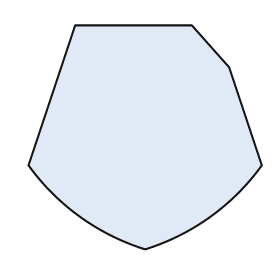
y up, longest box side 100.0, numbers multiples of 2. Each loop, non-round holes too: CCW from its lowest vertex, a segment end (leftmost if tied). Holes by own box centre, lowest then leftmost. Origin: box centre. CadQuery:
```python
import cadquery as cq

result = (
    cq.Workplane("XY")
    .moveTo(0.0, -48.0)
    .threePointArc((28.0, -34.0), (50.0, -12.0))
    .lineTo(36.0, 30.0)
    .lineTo(20.0, 48.0)
    .lineTo(-30.0, 48.0)
    .lineTo(-50.0, -12.0)
    .threePointArc((-28.0, -34.0), (0.0, -48.0))
    .close()
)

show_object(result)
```